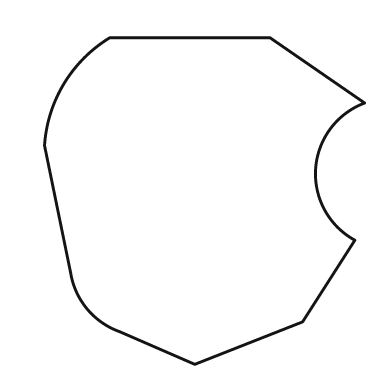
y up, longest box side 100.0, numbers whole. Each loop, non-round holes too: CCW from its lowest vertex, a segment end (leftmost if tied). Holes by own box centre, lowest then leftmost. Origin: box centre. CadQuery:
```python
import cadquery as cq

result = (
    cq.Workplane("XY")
    .moveTo(-3.0, -50.0)
    .lineTo(30.0, -37.0)
    .lineTo(46.0, -12.0)
    .threePointArc((34.0, 10.0), (49.0, 30.0))
    .lineTo(20.0, 50.0)
    .lineTo(-29.0, 50.0)
    .threePointArc((-43.0, 36.0), (-49.0, 17.0))
    .lineTo(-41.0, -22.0)
    .threePointArc((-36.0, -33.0), (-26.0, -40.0))
    .close()
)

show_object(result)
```